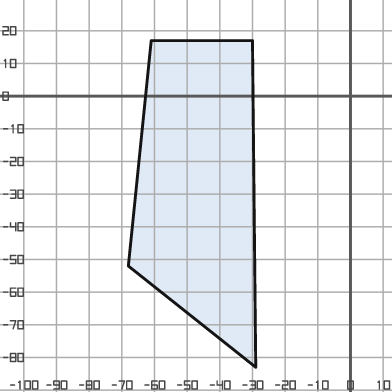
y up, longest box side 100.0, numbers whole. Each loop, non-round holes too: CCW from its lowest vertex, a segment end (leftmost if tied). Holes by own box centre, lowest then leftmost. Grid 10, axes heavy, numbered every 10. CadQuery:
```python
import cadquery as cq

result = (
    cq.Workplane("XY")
    .moveTo(-29.0, -83.0)
    .lineTo(-30.0, 17.0)
    .lineTo(-61.0, 17.0)
    .lineTo(-68.0, -52.0)
    .close()
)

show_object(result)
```